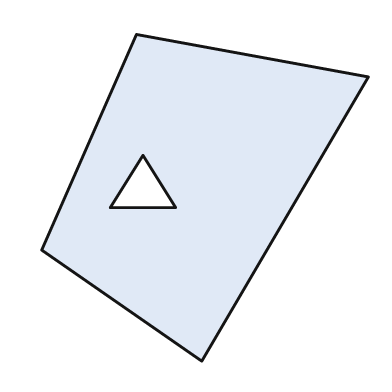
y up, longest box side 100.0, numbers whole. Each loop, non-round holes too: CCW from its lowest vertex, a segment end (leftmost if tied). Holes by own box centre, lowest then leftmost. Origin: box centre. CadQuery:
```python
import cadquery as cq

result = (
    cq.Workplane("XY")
    .moveTo(-1.0, -50.0)
    .lineTo(50.0, 37.0)
    .lineTo(-21.0, 50.0)
    .lineTo(-50.0, -16.0)
    .close()
    .moveTo(-29.0, -3.0)
    .lineTo(-9.0, -3.0)
    .lineTo(-19.0, 13.0)
    .close()
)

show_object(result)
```